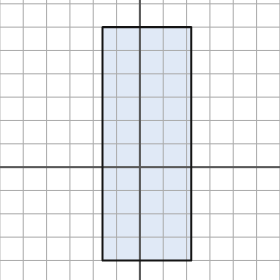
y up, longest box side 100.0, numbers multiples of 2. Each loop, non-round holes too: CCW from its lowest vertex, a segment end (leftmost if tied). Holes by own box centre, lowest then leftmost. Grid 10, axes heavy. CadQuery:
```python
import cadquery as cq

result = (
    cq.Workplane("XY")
    .moveTo(-16.0, -40.0)
    .lineTo(22.0, -40.0)
    .lineTo(22.0, 60.0)
    .lineTo(-16.0, 60.0)
    .close()
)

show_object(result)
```